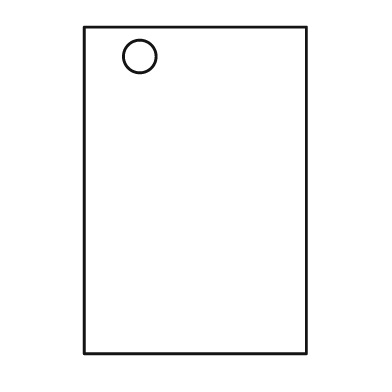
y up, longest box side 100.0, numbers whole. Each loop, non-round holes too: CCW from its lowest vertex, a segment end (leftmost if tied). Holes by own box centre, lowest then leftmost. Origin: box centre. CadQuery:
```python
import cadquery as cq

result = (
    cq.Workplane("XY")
    .moveTo(-34.0, -50.0)
    .lineTo(34.0, -50.0)
    .lineTo(34.0, 50.0)
    .lineTo(-34.0, 50.0)
    .close()
    .moveTo(-17.0, 41.0)
    .circle(5.0)
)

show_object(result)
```